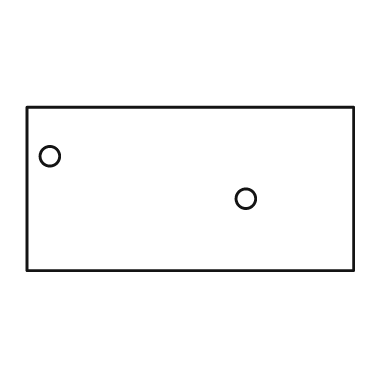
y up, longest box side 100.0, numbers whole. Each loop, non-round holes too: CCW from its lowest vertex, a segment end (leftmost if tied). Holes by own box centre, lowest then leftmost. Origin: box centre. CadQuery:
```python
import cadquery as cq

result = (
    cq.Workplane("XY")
    .moveTo(-50.0, -25.0)
    .lineTo(50.0, -25.0)
    .lineTo(50.0, 25.0)
    .lineTo(-50.0, 25.0)
    .close()
    .moveTo(17.0, -3.0)
    .circle(3.0)
    .moveTo(-43.0, 10.0)
    .circle(3.0)
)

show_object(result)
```